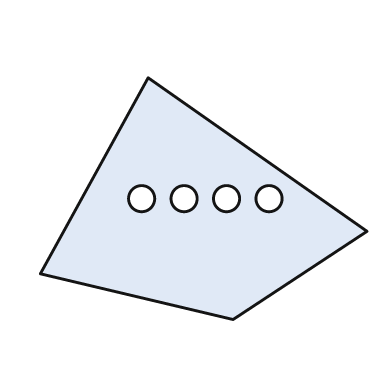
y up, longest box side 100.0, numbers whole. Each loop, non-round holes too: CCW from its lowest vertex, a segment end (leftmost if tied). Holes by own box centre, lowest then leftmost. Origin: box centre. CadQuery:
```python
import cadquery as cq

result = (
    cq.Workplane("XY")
    .moveTo(9.0, -37.0)
    .lineTo(50.0, -10.0)
    .lineTo(-17.0, 37.0)
    .lineTo(-50.0, -23.0)
    .close()
    .moveTo(-19.0, 0.0)
    .circle(4.0)
    .moveTo(-6.0, 0.0)
    .circle(4.0)
    .moveTo(7.0, 0.0)
    .circle(4.0)
    .moveTo(20.0, 0.0)
    .circle(4.0)
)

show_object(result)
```